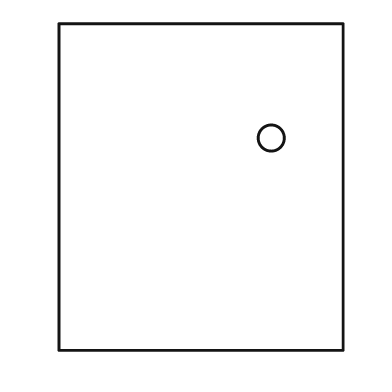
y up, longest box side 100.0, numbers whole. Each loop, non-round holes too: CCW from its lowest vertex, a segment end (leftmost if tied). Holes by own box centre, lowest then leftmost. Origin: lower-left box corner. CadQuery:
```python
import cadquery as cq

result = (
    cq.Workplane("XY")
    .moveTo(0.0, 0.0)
    .lineTo(87.0, 0.0)
    .lineTo(87.0, 100.0)
    .lineTo(0.0, 100.0)
    .close()
    .moveTo(65.0, 65.0)
    .circle(4.0)
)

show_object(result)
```